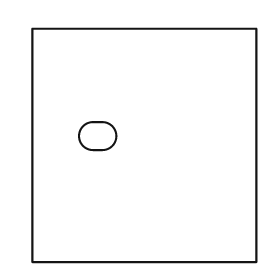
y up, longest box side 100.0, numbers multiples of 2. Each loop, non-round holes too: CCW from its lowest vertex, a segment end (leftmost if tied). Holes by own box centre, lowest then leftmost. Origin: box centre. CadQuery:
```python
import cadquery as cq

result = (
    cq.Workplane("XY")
    .moveTo(-48.0, -50.0)
    .lineTo(48.0, -50.0)
    .lineTo(48.0, 50.0)
    .lineTo(-48.0, 50.0)
    .close()
    .moveTo(-22.0, -2.0)
    .lineTo(-18.0, -2.0)
    .threePointArc((-12.0, 4.0), (-18.0, 10.0))
    .lineTo(-22.0, 10.0)
    .threePointArc((-28.0, 4.0), (-22.0, -2.0))
    .close()
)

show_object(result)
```